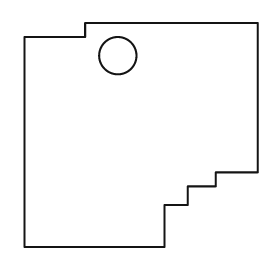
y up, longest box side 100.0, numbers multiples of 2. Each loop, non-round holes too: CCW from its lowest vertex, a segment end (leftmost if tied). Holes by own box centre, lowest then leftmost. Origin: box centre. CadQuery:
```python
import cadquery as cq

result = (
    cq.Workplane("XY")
    .moveTo(-50.0, -48.0)
    .lineTo(10.0, -48.0)
    .lineTo(10.0, -30.0)
    .lineTo(20.0, -30.0)
    .lineTo(20.0, -22.0)
    .lineTo(32.0, -22.0)
    .lineTo(32.0, -16.0)
    .lineTo(50.0, -16.0)
    .lineTo(50.0, 48.0)
    .lineTo(-24.0, 48.0)
    .lineTo(-24.0, 42.0)
    .lineTo(-50.0, 42.0)
    .close()
    .moveTo(-10.0, 34.0)
    .circle(8.0)
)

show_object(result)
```